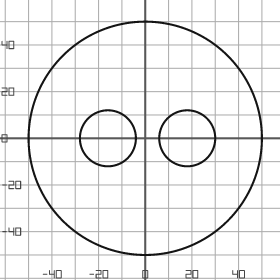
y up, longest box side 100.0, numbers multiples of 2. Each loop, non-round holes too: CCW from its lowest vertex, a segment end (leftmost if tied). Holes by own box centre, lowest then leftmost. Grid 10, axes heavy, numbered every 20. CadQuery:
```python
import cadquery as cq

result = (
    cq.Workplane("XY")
    .moveTo(0.0, 0.0)
    .circle(50.0)
    .moveTo(-16.0, 0.0)
    .circle(12.0)
    .moveTo(18.0, 0.0)
    .circle(12.0)
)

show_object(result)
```